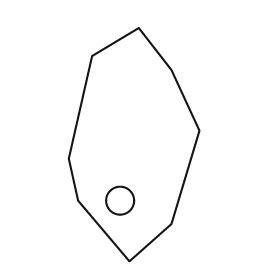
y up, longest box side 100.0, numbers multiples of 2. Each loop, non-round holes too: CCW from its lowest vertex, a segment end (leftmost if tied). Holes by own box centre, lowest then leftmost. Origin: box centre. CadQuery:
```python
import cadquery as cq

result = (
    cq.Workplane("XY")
    .moveTo(-2.0, -50.0)
    .lineTo(16.0, -34.0)
    .lineTo(28.0, 6.0)
    .lineTo(16.0, 32.0)
    .lineTo(2.0, 50.0)
    .lineTo(-18.0, 38.0)
    .lineTo(-28.0, -6.0)
    .lineTo(-24.0, -24.0)
    .close()
    .moveTo(-6.0, -24.0)
    .circle(6.0)
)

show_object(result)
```